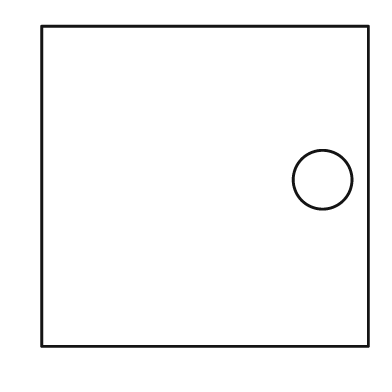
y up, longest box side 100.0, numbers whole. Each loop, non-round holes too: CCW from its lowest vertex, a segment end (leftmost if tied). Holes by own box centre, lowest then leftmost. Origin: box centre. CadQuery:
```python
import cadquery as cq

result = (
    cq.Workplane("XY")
    .moveTo(-50.0, -49.0)
    .lineTo(50.0, -49.0)
    .lineTo(50.0, 49.0)
    .lineTo(-50.0, 49.0)
    .close()
    .moveTo(36.0, 2.0)
    .circle(9.0)
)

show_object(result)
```